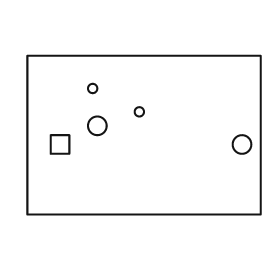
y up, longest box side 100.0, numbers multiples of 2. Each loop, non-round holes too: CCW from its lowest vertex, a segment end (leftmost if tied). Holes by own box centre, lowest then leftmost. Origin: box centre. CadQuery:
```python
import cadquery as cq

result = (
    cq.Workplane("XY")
    .moveTo(-50.0, -34.0)
    .lineTo(50.0, -34.0)
    .lineTo(50.0, 34.0)
    .lineTo(-50.0, 34.0)
    .close()
    .moveTo(-40.0, -8.0)
    .lineTo(-32.0, -8.0)
    .lineTo(-32.0, 0.0)
    .lineTo(-40.0, 0.0)
    .close()
    .moveTo(42.0, -4.0)
    .circle(4.0)
    .moveTo(-20.0, 4.0)
    .circle(4.0)
    .moveTo(-2.0, 10.0)
    .circle(2.0)
    .moveTo(-22.0, 20.0)
    .circle(2.0)
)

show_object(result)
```